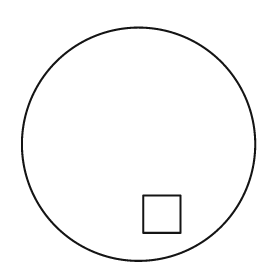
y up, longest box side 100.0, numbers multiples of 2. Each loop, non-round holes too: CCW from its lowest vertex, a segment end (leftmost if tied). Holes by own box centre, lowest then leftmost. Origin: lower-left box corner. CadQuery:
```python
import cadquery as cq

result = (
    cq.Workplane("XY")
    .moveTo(50.0, 50.0)
    .circle(50.0)
    .moveTo(52.0, 12.0)
    .lineTo(68.0, 12.0)
    .lineTo(68.0, 28.0)
    .lineTo(52.0, 28.0)
    .close()
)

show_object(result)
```